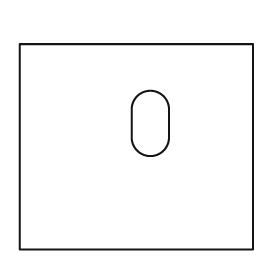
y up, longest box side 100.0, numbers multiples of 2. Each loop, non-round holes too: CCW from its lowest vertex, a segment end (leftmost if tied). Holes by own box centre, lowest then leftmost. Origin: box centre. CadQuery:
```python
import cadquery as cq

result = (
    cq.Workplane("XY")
    .moveTo(-50.0, -44.0)
    .lineTo(50.0, -44.0)
    .lineTo(50.0, 44.0)
    .lineTo(-50.0, 44.0)
    .close()
    .moveTo(-2.0, 4.0)
    .threePointArc((6.0, -4.0), (14.0, 4.0))
    .lineTo(14.0, 16.0)
    .threePointArc((6.0, 24.0), (-2.0, 16.0))
    .close()
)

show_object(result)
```